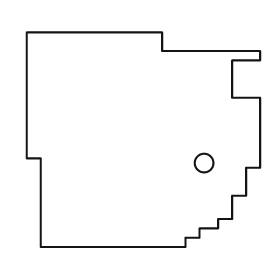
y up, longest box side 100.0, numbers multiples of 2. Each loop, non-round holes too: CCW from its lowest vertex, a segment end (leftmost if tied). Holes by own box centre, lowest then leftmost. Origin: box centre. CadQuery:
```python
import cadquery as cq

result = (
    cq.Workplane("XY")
    .moveTo(-44.0, -46.0)
    .lineTo(18.0, -46.0)
    .lineTo(18.0, -42.0)
    .lineTo(24.0, -42.0)
    .lineTo(24.0, -38.0)
    .lineTo(32.0, -38.0)
    .lineTo(32.0, -34.0)
    .lineTo(38.0, -34.0)
    .lineTo(38.0, -24.0)
    .lineTo(44.0, -24.0)
    .lineTo(44.0, -12.0)
    .lineTo(50.0, -12.0)
    .lineTo(50.0, 18.0)
    .lineTo(38.0, 18.0)
    .lineTo(38.0, 34.0)
    .lineTo(50.0, 34.0)
    .lineTo(50.0, 38.0)
    .lineTo(8.0, 38.0)
    .lineTo(8.0, 46.0)
    .lineTo(-50.0, 46.0)
    .lineTo(-50.0, -8.0)
    .lineTo(-44.0, -8.0)
    .close()
    .moveTo(26.0, -10.0)
    .circle(4.0)
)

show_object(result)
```